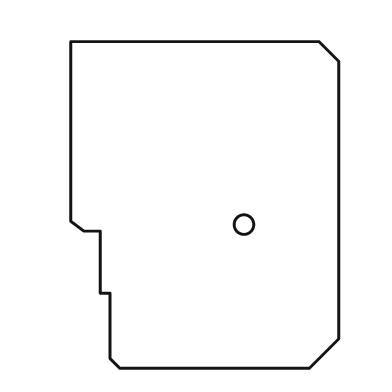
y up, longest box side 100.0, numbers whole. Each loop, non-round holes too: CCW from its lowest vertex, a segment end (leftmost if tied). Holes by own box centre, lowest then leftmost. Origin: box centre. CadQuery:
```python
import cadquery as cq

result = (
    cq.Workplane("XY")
    .moveTo(-26.0, -50.0)
    .lineTo(32.0, -50.0)
    .lineTo(41.0, -41.0)
    .lineTo(41.0, 44.0)
    .lineTo(35.0, 50.0)
    .lineTo(-41.0, 50.0)
    .lineTo(-41.0, -5.0)
    .lineTo(-37.0, -8.0)
    .lineTo(-32.0, -8.0)
    .lineTo(-32.0, -27.0)
    .lineTo(-29.0, -27.0)
    .lineTo(-29.0, -47.0)
    .close()
    .moveTo(12.0, -6.0)
    .circle(3.0)
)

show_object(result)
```